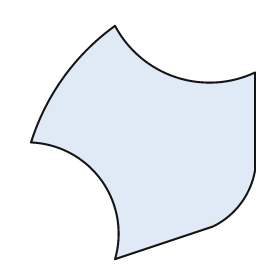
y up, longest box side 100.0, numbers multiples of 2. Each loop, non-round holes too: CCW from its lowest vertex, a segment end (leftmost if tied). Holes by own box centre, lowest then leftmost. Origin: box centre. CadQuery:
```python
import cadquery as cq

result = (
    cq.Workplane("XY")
    .moveTo(-12.0, -50.0)
    .lineTo(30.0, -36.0)
    .threePointArc((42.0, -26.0), (48.0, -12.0))
    .lineTo(48.0, 30.0)
    .threePointArc((14.0, 28.0), (-12.0, 50.0))
    .threePointArc((-34.0, 28.0), (-48.0, 0.0))
    .threePointArc((-18.0, -16.0), (-12.0, -50.0))
    .close()
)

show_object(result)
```